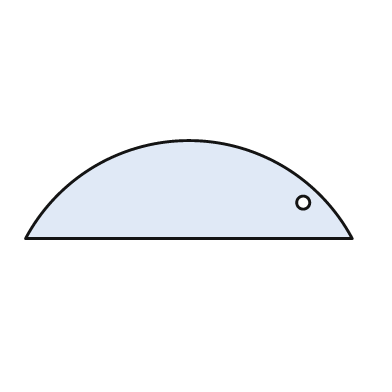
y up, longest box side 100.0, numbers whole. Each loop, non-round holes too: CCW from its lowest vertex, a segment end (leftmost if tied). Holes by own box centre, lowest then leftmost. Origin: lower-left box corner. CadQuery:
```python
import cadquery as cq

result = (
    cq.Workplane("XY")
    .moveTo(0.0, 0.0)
    .lineTo(100.0, 0.0)
    .threePointArc((50.0, 30.0), (0.0, 0.0))
    .close()
    .moveTo(85.0, 11.0)
    .circle(2.0)
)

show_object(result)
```